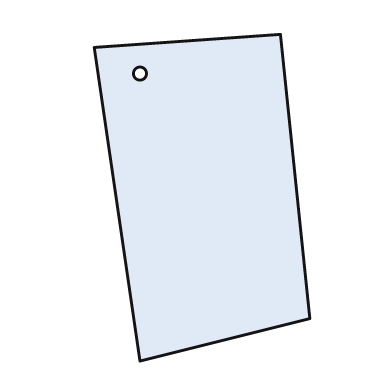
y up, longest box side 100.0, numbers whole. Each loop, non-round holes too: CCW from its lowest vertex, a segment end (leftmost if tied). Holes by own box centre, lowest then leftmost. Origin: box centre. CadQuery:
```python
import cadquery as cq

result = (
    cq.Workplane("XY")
    .moveTo(-19.0, -50.0)
    .lineTo(33.0, -37.0)
    .lineTo(24.0, 50.0)
    .lineTo(-33.0, 46.0)
    .close()
    .moveTo(-19.0, 38.0)
    .circle(2.0)
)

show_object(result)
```